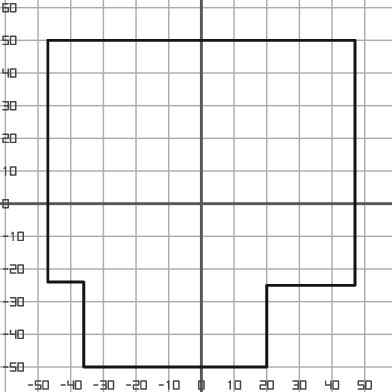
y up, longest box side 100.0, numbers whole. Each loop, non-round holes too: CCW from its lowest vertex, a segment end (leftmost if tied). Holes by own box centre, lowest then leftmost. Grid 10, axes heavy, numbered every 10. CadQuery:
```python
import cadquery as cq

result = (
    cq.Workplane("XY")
    .moveTo(-36.0, -50.0)
    .lineTo(20.0, -50.0)
    .lineTo(20.0, -25.0)
    .lineTo(47.0, -25.0)
    .lineTo(47.0, 50.0)
    .lineTo(-47.0, 50.0)
    .lineTo(-47.0, -24.0)
    .lineTo(-36.0, -24.0)
    .close()
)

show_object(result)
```